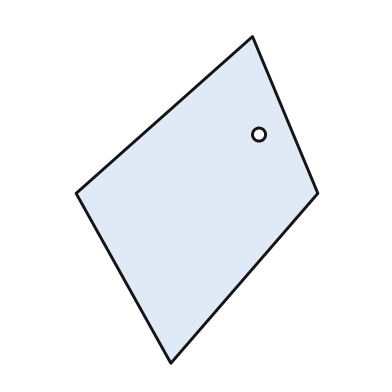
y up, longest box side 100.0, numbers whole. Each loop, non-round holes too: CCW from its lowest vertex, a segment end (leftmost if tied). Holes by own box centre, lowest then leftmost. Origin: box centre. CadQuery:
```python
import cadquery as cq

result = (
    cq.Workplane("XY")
    .moveTo(-8.0, -50.0)
    .lineTo(37.0, 2.0)
    .lineTo(17.0, 50.0)
    .lineTo(-37.0, 2.0)
    .close()
    .moveTo(19.0, 20.0)
    .circle(2.0)
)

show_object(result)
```